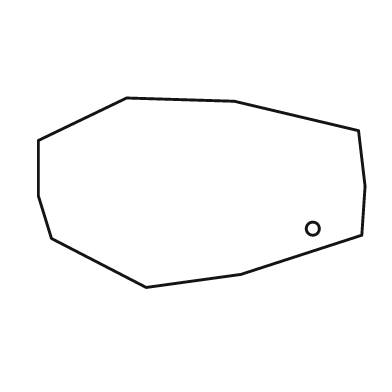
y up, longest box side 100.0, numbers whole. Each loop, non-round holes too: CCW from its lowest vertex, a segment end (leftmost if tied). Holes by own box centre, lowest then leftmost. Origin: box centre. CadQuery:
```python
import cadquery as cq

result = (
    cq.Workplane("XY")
    .moveTo(-17.0, -29.0)
    .lineTo(12.0, -25.0)
    .lineTo(49.0, -13.0)
    .lineTo(50.0, 2.0)
    .lineTo(48.0, 19.0)
    .lineTo(10.0, 28.0)
    .lineTo(-23.0, 29.0)
    .lineTo(-50.0, 16.0)
    .lineTo(-50.0, -1.0)
    .lineTo(-46.0, -14.0)
    .close()
    .moveTo(34.0, -11.0)
    .circle(2.0)
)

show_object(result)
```